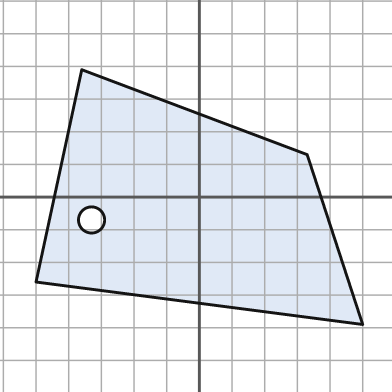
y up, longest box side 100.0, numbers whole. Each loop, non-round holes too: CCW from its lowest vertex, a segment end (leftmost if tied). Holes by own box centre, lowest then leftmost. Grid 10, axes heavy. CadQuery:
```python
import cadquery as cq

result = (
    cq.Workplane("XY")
    .moveTo(50.0, -39.0)
    .lineTo(33.0, 13.0)
    .lineTo(-36.0, 39.0)
    .lineTo(-50.0, -26.0)
    .close()
    .moveTo(-33.0, -7.0)
    .circle(4.0)
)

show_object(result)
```